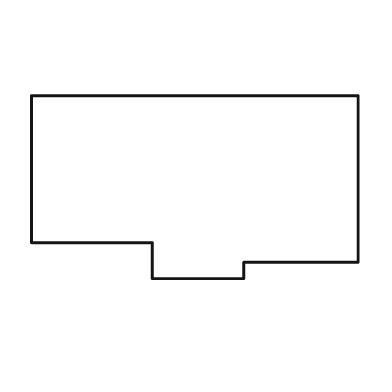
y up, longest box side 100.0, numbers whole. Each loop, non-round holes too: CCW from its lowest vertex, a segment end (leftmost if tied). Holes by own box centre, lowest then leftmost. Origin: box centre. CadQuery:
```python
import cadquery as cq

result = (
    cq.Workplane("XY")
    .moveTo(-13.0, -28.0)
    .lineTo(15.0, -28.0)
    .lineTo(15.0, -23.0)
    .lineTo(50.0, -23.0)
    .lineTo(50.0, 28.0)
    .lineTo(-50.0, 28.0)
    .lineTo(-50.0, -17.0)
    .lineTo(-13.0, -17.0)
    .close()
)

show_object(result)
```